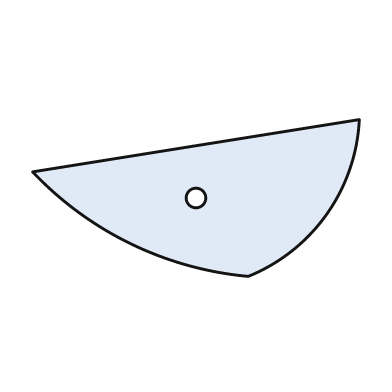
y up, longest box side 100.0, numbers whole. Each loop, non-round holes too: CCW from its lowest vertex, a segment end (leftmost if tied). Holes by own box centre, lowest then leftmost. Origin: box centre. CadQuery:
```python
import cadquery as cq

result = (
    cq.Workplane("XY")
    .moveTo(16.0, -24.0)
    .threePointArc((40.0, -5.0), (50.0, 24.0))
    .lineTo(-50.0, 8.0)
    .threePointArc((-20.0, -14.0), (16.0, -24.0))
    .close()
    .moveTo(0.0, 0.0)
    .circle(3.0)
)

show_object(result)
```